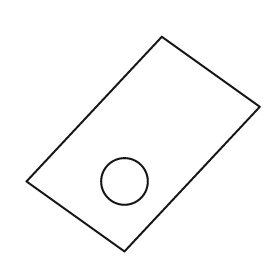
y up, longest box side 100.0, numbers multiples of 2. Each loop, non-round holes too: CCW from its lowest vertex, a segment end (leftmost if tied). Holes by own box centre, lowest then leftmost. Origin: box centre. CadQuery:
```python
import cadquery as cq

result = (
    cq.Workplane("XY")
    .moveTo(-8.0, -46.0)
    .lineTo(50.0, 16.0)
    .lineTo(8.0, 46.0)
    .lineTo(-50.0, -16.0)
    .close()
    .moveTo(-8.0, -16.0)
    .circle(10.0)
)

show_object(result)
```